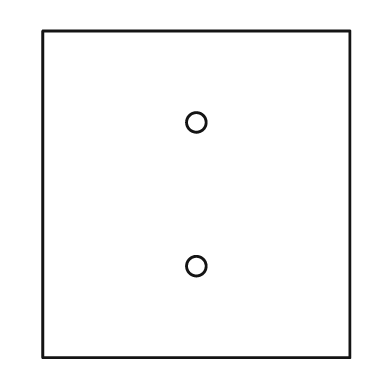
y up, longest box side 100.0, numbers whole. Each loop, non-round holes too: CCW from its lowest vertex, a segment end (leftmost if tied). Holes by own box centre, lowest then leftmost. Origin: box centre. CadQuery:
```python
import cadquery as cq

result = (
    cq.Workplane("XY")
    .moveTo(-47.0, -50.0)
    .lineTo(47.0, -50.0)
    .lineTo(47.0, 50.0)
    .lineTo(-47.0, 50.0)
    .close()
    .moveTo(0.0, -22.0)
    .circle(3.0)
    .moveTo(0.0, 22.0)
    .circle(3.0)
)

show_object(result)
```